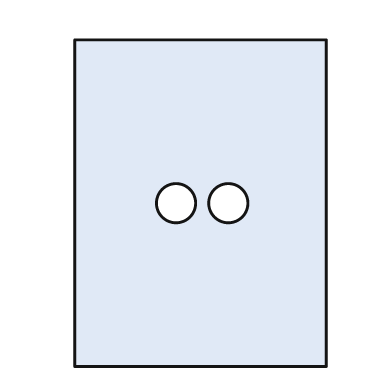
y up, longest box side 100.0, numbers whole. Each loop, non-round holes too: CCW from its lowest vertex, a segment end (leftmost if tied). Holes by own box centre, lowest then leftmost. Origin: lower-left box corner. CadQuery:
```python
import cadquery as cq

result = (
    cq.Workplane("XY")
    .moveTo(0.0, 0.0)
    .lineTo(77.0, 0.0)
    .lineTo(77.0, 100.0)
    .lineTo(0.0, 100.0)
    .close()
    .moveTo(31.0, 50.0)
    .circle(6.0)
    .moveTo(47.0, 50.0)
    .circle(6.0)
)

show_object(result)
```